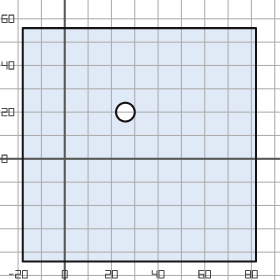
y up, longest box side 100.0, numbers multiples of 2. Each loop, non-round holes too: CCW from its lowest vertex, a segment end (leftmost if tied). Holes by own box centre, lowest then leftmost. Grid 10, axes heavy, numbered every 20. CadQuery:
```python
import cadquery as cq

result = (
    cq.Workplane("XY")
    .moveTo(-18.0, -44.0)
    .lineTo(82.0, -44.0)
    .lineTo(82.0, 56.0)
    .lineTo(-18.0, 56.0)
    .close()
    .moveTo(26.0, 20.0)
    .circle(4.0)
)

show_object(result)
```